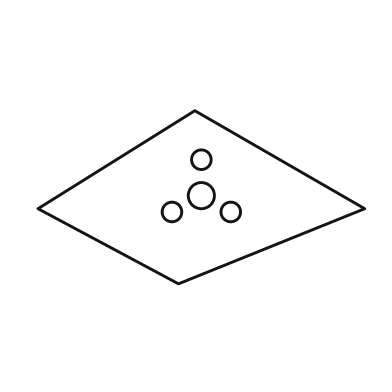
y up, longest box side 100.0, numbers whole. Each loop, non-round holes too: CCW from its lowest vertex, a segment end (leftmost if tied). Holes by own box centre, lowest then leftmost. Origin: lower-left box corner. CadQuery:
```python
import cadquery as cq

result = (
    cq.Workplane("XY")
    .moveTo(43.0, 0.0)
    .lineTo(100.0, 23.0)
    .lineTo(48.0, 53.0)
    .lineTo(0.0, 23.0)
    .close()
    .moveTo(41.0, 22.0)
    .circle(3.0)
    .moveTo(59.0, 22.0)
    .circle(3.0)
    .moveTo(50.0, 27.0)
    .circle(4.0)
    .moveTo(50.0, 38.0)
    .circle(3.0)
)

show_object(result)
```